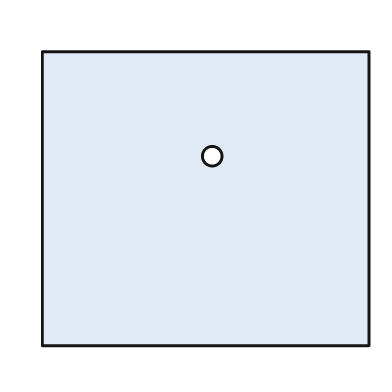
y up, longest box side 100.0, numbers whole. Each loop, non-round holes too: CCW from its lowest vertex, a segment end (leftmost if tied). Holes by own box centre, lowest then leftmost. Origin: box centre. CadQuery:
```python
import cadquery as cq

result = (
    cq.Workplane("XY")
    .moveTo(-50.0, -45.0)
    .lineTo(50.0, -45.0)
    .lineTo(50.0, 45.0)
    .lineTo(-50.0, 45.0)
    .close()
    .moveTo(2.0, 13.0)
    .circle(3.0)
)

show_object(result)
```